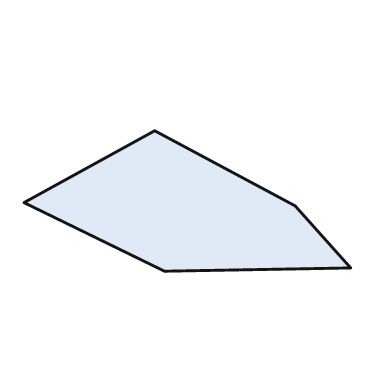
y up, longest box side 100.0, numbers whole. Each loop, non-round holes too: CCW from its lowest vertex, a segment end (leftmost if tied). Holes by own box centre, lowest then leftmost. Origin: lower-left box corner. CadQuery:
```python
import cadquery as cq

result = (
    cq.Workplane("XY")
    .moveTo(43.0, 0.0)
    .lineTo(100.0, 1.0)
    .lineTo(83.0, 20.0)
    .lineTo(40.0, 43.0)
    .lineTo(0.0, 21.0)
    .close()
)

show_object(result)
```